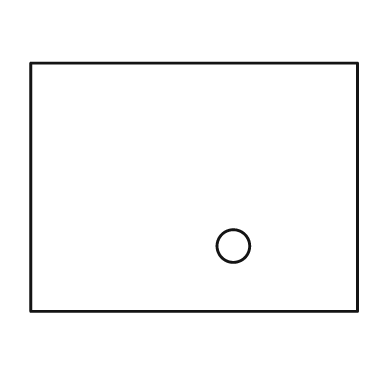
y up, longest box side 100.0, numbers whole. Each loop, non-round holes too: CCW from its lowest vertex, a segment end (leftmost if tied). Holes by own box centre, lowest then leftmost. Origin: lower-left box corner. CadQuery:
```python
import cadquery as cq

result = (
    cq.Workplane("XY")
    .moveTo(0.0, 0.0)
    .lineTo(100.0, 0.0)
    .lineTo(100.0, 76.0)
    .lineTo(0.0, 76.0)
    .close()
    .moveTo(62.0, 20.0)
    .circle(5.0)
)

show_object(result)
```